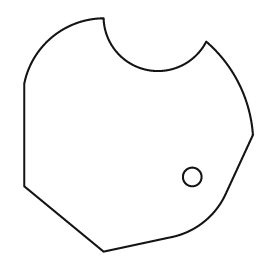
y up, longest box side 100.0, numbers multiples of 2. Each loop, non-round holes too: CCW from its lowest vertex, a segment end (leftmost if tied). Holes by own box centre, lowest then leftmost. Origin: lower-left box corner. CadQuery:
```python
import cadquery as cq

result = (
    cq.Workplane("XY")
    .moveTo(34.0, 0.0)
    .lineTo(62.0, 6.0)
    .threePointArc((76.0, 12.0), (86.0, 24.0))
    .lineTo(98.0, 50.0)
    .threePointArc((92.0, 72.0), (78.0, 90.0))
    .threePointArc((52.0, 78.0), (34.0, 100.0))
    .threePointArc((12.0, 92.0), (0.0, 72.0))
    .lineTo(0.0, 28.0)
    .close()
    .moveTo(72.0, 32.0)
    .circle(4.0)
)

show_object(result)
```